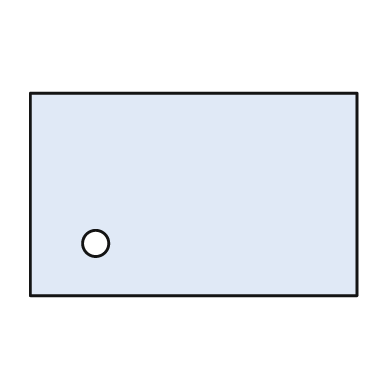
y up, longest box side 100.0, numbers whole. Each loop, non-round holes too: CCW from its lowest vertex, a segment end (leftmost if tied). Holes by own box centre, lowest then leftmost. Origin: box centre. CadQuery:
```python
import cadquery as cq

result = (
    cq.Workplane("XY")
    .moveTo(-50.0, -31.0)
    .lineTo(50.0, -31.0)
    .lineTo(50.0, 31.0)
    .lineTo(-50.0, 31.0)
    .close()
    .moveTo(-30.0, -15.0)
    .circle(4.0)
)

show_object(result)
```